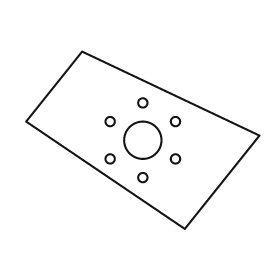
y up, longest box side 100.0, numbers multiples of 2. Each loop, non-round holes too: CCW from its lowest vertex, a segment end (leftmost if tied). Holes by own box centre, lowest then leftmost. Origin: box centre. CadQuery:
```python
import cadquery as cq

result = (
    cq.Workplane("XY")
    .moveTo(18.0, -38.0)
    .lineTo(50.0, 2.0)
    .lineTo(-26.0, 38.0)
    .lineTo(-50.0, 8.0)
    .close()
    .moveTo(0.0, -16.0)
    .circle(2.0)
    .moveTo(-14.0, -8.0)
    .circle(2.0)
    .moveTo(14.0, -8.0)
    .circle(2.0)
    .moveTo(0.0, 0.0)
    .circle(8.0)
    .moveTo(-14.0, 8.0)
    .circle(2.0)
    .moveTo(14.0, 8.0)
    .circle(2.0)
    .moveTo(0.0, 16.0)
    .circle(2.0)
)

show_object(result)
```